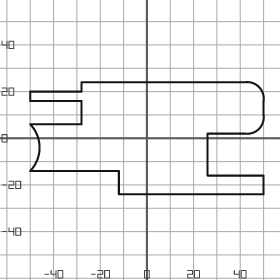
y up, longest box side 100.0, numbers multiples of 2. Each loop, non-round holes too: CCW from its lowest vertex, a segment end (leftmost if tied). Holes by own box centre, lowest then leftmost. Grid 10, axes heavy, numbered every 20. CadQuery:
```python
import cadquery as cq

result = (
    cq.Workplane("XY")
    .moveTo(-12.0, -24.0)
    .lineTo(50.0, -24.0)
    .lineTo(50.0, -16.0)
    .lineTo(26.0, -16.0)
    .lineTo(26.0, 2.0)
    .lineTo(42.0, 2.0)
    .threePointArc((48.0, 4.0), (50.0, 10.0))
    .lineTo(50.0, 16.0)
    .threePointArc((48.0, 22.0), (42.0, 24.0))
    .lineTo(-28.0, 24.0)
    .lineTo(-28.0, 20.0)
    .lineTo(-50.0, 20.0)
    .lineTo(-50.0, 16.0)
    .lineTo(-28.0, 16.0)
    .lineTo(-28.0, 6.0)
    .lineTo(-50.0, 6.0)
    .threePointArc((-46.0, -4.0), (-50.0, -14.0))
    .lineTo(-12.0, -14.0)
    .close()
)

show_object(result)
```